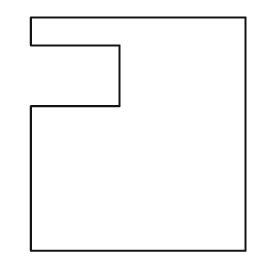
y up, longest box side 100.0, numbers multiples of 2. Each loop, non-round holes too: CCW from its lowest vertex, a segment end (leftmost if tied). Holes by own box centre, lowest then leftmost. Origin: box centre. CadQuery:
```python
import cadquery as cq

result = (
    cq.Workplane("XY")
    .moveTo(-46.0, -50.0)
    .lineTo(46.0, -50.0)
    .lineTo(46.0, 50.0)
    .lineTo(-46.0, 50.0)
    .lineTo(-46.0, 38.0)
    .lineTo(-8.0, 38.0)
    .lineTo(-8.0, 12.0)
    .lineTo(-46.0, 12.0)
    .close()
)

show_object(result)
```